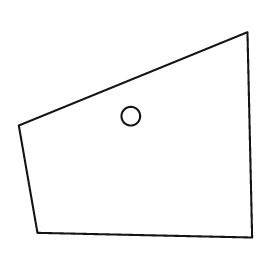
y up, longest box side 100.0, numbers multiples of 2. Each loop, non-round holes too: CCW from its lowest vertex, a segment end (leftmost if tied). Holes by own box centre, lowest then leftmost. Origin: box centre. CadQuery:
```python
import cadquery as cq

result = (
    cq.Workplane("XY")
    .moveTo(50.0, -44.0)
    .lineTo(48.0, 44.0)
    .lineTo(-50.0, 4.0)
    .lineTo(-42.0, -42.0)
    .close()
    .moveTo(-2.0, 8.0)
    .circle(4.0)
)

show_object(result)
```